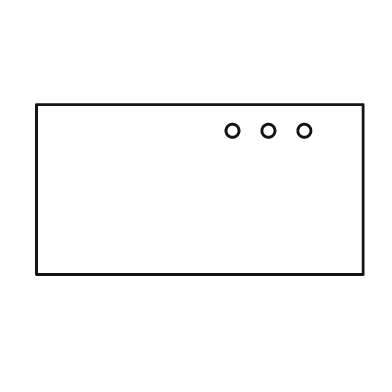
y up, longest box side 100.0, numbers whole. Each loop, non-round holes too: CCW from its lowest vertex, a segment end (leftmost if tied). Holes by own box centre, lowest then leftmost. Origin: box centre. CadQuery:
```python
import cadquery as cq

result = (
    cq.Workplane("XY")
    .moveTo(-50.0, -26.0)
    .lineTo(50.0, -26.0)
    .lineTo(50.0, 26.0)
    .lineTo(-50.0, 26.0)
    .close()
    .moveTo(10.0, 18.0)
    .circle(2.0)
    .moveTo(21.0, 18.0)
    .circle(2.0)
    .moveTo(32.0, 18.0)
    .circle(2.0)
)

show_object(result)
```